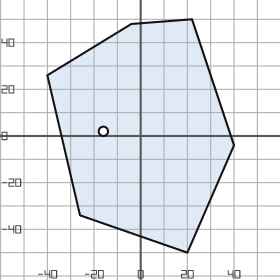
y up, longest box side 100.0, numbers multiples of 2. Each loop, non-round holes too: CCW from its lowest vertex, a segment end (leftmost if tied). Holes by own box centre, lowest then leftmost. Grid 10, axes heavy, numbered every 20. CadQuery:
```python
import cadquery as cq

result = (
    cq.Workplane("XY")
    .moveTo(20.0, -50.0)
    .lineTo(40.0, -4.0)
    .lineTo(22.0, 50.0)
    .lineTo(-4.0, 48.0)
    .lineTo(-40.0, 26.0)
    .lineTo(-26.0, -34.0)
    .close()
    .moveTo(-16.0, 2.0)
    .circle(2.0)
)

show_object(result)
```